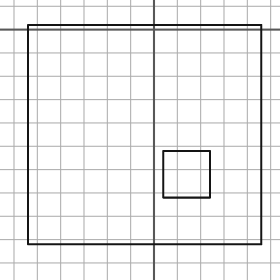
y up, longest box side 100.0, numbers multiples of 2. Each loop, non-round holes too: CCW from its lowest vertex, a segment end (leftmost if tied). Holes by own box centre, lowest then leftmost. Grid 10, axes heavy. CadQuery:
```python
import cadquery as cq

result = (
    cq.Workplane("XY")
    .moveTo(-54.0, -92.0)
    .lineTo(46.0, -92.0)
    .lineTo(46.0, 2.0)
    .lineTo(-54.0, 2.0)
    .close()
    .moveTo(4.0, -72.0)
    .lineTo(24.0, -72.0)
    .lineTo(24.0, -52.0)
    .lineTo(4.0, -52.0)
    .close()
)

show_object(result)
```